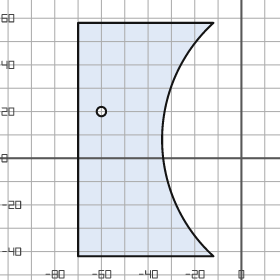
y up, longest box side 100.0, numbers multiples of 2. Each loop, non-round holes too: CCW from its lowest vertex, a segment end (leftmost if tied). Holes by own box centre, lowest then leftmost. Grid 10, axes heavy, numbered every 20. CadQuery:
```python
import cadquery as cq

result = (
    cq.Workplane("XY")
    .moveTo(-70.0, -42.0)
    .lineTo(-12.0, -42.0)
    .threePointArc((-34.0, 8.0), (-12.0, 58.0))
    .lineTo(-70.0, 58.0)
    .close()
    .moveTo(-60.0, 20.0)
    .circle(2.0)
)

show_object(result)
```